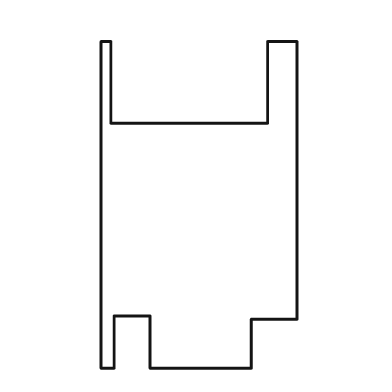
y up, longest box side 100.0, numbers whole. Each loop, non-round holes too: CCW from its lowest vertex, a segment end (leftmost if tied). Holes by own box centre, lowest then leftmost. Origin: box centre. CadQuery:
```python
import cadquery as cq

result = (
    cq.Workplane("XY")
    .moveTo(-30.0, -50.0)
    .lineTo(-26.0, -50.0)
    .lineTo(-26.0, -34.0)
    .lineTo(-15.0, -34.0)
    .lineTo(-15.0, -50.0)
    .lineTo(16.0, -50.0)
    .lineTo(16.0, -35.0)
    .lineTo(30.0, -35.0)
    .lineTo(30.0, 50.0)
    .lineTo(21.0, 50.0)
    .lineTo(21.0, 25.0)
    .lineTo(-27.0, 25.0)
    .lineTo(-27.0, 50.0)
    .lineTo(-30.0, 50.0)
    .close()
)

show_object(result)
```